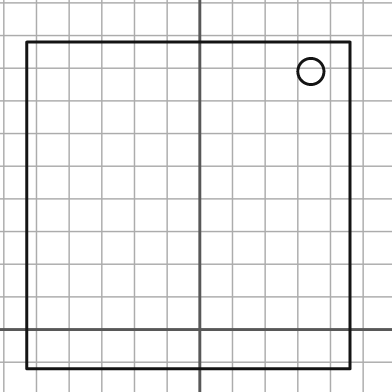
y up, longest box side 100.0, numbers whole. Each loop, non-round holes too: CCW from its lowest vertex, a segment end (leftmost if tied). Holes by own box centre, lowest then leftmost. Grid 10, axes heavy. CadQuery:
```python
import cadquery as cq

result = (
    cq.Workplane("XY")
    .moveTo(-53.0, -12.0)
    .lineTo(46.0, -12.0)
    .lineTo(46.0, 88.0)
    .lineTo(-53.0, 88.0)
    .close()
    .moveTo(34.0, 79.0)
    .circle(4.0)
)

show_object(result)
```